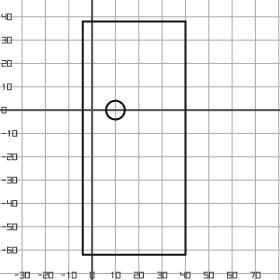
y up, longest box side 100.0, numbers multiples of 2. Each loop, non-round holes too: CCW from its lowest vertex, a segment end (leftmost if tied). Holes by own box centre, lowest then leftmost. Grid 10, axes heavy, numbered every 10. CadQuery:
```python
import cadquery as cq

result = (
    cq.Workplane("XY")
    .moveTo(-4.0, -62.0)
    .lineTo(40.0, -62.0)
    .lineTo(40.0, 38.0)
    .lineTo(-4.0, 38.0)
    .close()
    .moveTo(10.0, 0.0)
    .circle(4.0)
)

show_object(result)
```